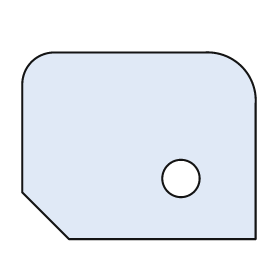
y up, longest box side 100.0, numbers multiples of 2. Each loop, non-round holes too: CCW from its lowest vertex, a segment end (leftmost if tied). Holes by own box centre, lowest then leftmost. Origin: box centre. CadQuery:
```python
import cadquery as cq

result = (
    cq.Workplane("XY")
    .moveTo(-30.0, -40.0)
    .lineTo(50.0, -40.0)
    .lineTo(50.0, 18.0)
    .threePointArc((44.0, 34.0), (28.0, 40.0))
    .lineTo(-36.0, 40.0)
    .threePointArc((-46.0, 36.0), (-50.0, 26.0))
    .lineTo(-50.0, -20.0)
    .close()
    .moveTo(18.0, -14.0)
    .circle(8.0)
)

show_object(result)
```